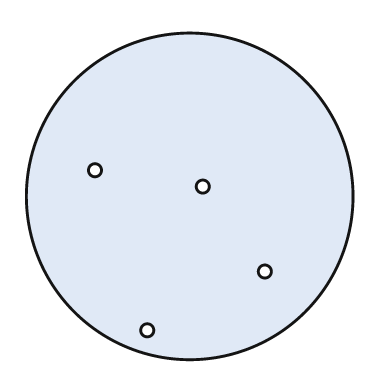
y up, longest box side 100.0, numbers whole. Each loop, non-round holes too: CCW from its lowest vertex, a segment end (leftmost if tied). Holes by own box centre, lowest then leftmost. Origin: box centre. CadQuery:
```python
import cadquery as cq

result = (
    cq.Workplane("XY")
    .moveTo(0.0, 0.0)
    .circle(50.0)
    .moveTo(-13.0, -41.0)
    .circle(2.0)
    .moveTo(23.0, -23.0)
    .circle(2.0)
    .moveTo(4.0, 3.0)
    .circle(2.0)
    .moveTo(-29.0, 8.0)
    .circle(2.0)
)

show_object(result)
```